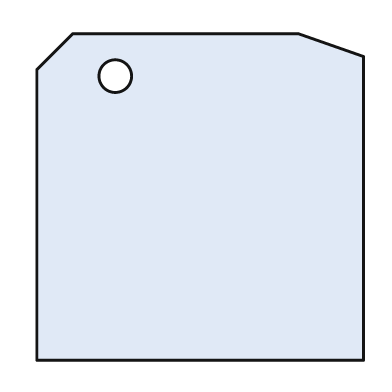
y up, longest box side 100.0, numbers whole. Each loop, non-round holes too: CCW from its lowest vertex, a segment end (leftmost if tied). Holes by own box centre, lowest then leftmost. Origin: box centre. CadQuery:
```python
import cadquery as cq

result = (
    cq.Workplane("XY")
    .moveTo(-50.0, -50.0)
    .lineTo(50.0, -50.0)
    .lineTo(50.0, 43.0)
    .lineTo(30.0, 50.0)
    .lineTo(-39.0, 50.0)
    .lineTo(-50.0, 39.0)
    .close()
    .moveTo(-26.0, 37.0)
    .circle(5.0)
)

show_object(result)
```